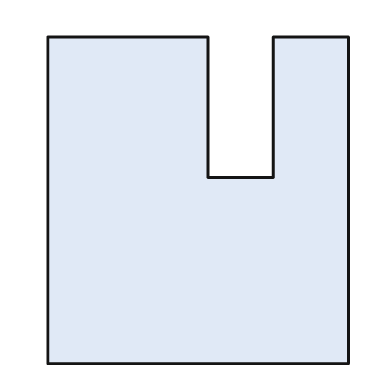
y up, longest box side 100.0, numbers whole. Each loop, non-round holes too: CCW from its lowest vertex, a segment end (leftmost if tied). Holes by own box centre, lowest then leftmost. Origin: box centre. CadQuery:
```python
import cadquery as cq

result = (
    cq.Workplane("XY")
    .moveTo(-46.0, -50.0)
    .lineTo(46.0, -50.0)
    .lineTo(46.0, 50.0)
    .lineTo(23.0, 50.0)
    .lineTo(23.0, 7.0)
    .lineTo(3.0, 7.0)
    .lineTo(3.0, 50.0)
    .lineTo(-46.0, 50.0)
    .close()
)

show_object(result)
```